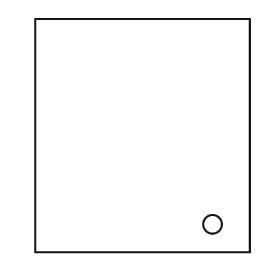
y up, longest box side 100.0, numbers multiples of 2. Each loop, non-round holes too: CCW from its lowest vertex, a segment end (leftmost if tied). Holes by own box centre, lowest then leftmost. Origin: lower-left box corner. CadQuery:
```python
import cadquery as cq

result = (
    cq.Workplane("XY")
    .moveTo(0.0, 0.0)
    .lineTo(92.0, 0.0)
    .lineTo(92.0, 100.0)
    .lineTo(0.0, 100.0)
    .close()
    .moveTo(76.0, 12.0)
    .circle(4.0)
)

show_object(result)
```